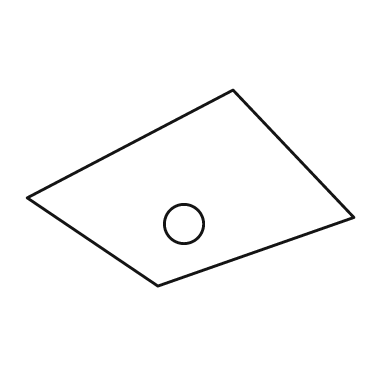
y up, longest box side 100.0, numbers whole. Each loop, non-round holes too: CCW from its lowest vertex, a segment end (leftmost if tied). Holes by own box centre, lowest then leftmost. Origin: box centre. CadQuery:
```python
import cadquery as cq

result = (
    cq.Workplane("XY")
    .moveTo(-10.0, -30.0)
    .lineTo(50.0, -9.0)
    .lineTo(13.0, 30.0)
    .lineTo(-50.0, -3.0)
    .close()
    .moveTo(-2.0, -11.0)
    .circle(6.0)
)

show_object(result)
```